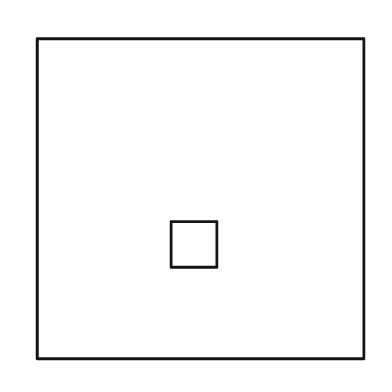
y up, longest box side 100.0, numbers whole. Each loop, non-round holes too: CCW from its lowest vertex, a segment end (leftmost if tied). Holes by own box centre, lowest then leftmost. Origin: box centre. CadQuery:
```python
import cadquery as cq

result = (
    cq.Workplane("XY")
    .moveTo(-50.0, -49.0)
    .lineTo(50.0, -49.0)
    .lineTo(50.0, 49.0)
    .lineTo(-50.0, 49.0)
    .close()
    .moveTo(-9.0, -21.0)
    .lineTo(5.0, -21.0)
    .lineTo(5.0, -7.0)
    .lineTo(-9.0, -7.0)
    .close()
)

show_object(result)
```